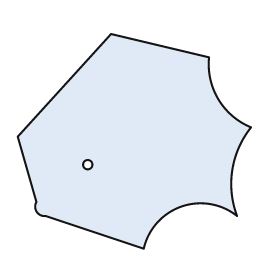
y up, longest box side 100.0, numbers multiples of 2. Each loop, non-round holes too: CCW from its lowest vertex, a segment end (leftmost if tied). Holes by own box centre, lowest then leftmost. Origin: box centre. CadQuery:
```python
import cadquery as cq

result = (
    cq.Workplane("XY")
    .moveTo(4.0, -46.0)
    .threePointArc((20.0, -28.0), (44.0, -32.0))
    .threePointArc((42.0, -12.0), (50.0, 6.0))
    .threePointArc((36.0, 18.0), (32.0, 36.0))
    .lineTo(-10.0, 46.0)
    .lineTo(-50.0, 2.0)
    .lineTo(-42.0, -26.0)
    .threePointArc((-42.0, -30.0), (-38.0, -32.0))
    .close()
    .moveTo(-20.0, -10.0)
    .circle(2.0)
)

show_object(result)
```